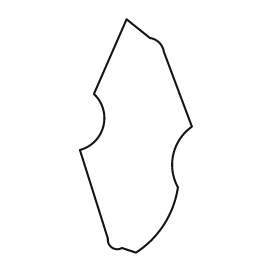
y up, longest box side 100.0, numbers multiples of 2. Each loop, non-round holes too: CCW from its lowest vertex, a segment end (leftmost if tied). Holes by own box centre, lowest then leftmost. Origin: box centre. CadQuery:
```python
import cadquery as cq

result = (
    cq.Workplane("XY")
    .moveTo(0.0, -50.0)
    .threePointArc((12.0, -38.0), (18.0, -22.0))
    .threePointArc((16.0, -8.0), (24.0, 4.0))
    .lineTo(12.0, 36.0)
    .threePointArc((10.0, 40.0), (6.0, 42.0))
    .lineTo(-4.0, 50.0)
    .lineTo(-18.0, 18.0)
    .threePointArc((-14.0, 4.0), (-24.0, -6.0))
    .lineTo(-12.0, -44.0)
    .threePointArc((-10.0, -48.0), (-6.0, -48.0))
    .close()
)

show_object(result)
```